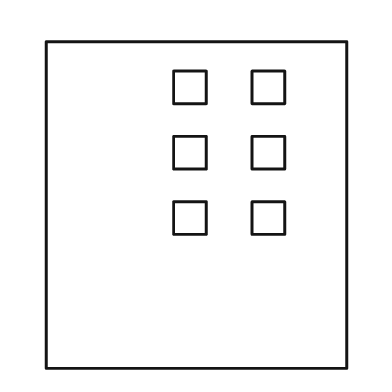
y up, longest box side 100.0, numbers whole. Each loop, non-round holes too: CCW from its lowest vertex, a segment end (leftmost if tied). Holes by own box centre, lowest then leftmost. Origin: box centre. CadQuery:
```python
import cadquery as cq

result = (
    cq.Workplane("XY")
    .moveTo(-46.0, -50.0)
    .lineTo(46.0, -50.0)
    .lineTo(46.0, 50.0)
    .lineTo(-46.0, 50.0)
    .close()
    .moveTo(-7.0, -9.0)
    .lineTo(3.0, -9.0)
    .lineTo(3.0, 1.0)
    .lineTo(-7.0, 1.0)
    .close()
    .moveTo(17.0, -9.0)
    .lineTo(27.0, -9.0)
    .lineTo(27.0, 1.0)
    .lineTo(17.0, 1.0)
    .close()
    .moveTo(-7.0, 11.0)
    .lineTo(3.0, 11.0)
    .lineTo(3.0, 21.0)
    .lineTo(-7.0, 21.0)
    .close()
    .moveTo(17.0, 11.0)
    .lineTo(27.0, 11.0)
    .lineTo(27.0, 21.0)
    .lineTo(17.0, 21.0)
    .close()
    .moveTo(-7.0, 31.0)
    .lineTo(3.0, 31.0)
    .lineTo(3.0, 41.0)
    .lineTo(-7.0, 41.0)
    .close()
    .moveTo(17.0, 31.0)
    .lineTo(27.0, 31.0)
    .lineTo(27.0, 41.0)
    .lineTo(17.0, 41.0)
    .close()
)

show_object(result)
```